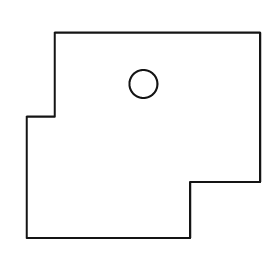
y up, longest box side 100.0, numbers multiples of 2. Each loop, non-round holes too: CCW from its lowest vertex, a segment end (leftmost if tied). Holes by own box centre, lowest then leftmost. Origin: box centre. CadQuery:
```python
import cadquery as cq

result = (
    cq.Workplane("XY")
    .moveTo(-50.0, -44.0)
    .lineTo(20.0, -44.0)
    .lineTo(20.0, -20.0)
    .lineTo(50.0, -20.0)
    .lineTo(50.0, 44.0)
    .lineTo(-38.0, 44.0)
    .lineTo(-38.0, 8.0)
    .lineTo(-50.0, 8.0)
    .close()
    .moveTo(0.0, 22.0)
    .circle(6.0)
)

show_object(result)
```